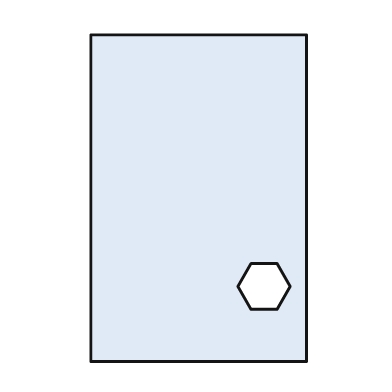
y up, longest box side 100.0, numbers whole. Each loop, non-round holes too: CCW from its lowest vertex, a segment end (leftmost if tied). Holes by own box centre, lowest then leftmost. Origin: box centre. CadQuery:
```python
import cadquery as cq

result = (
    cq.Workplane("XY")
    .moveTo(-33.0, -50.0)
    .lineTo(33.0, -50.0)
    .lineTo(33.0, 50.0)
    .lineTo(-33.0, 50.0)
    .close()
    .moveTo(16.0, -34.0)
    .lineTo(24.0, -34.0)
    .lineTo(28.0, -27.0)
    .lineTo(24.0, -20.0)
    .lineTo(16.0, -20.0)
    .lineTo(12.0, -27.0)
    .close()
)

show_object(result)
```